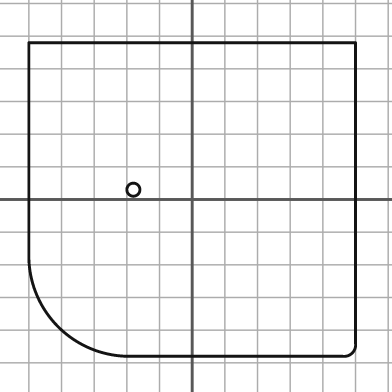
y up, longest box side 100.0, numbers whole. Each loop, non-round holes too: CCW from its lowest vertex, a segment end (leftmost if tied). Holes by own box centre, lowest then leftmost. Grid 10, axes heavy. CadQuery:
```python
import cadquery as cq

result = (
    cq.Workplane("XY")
    .moveTo(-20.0, -48.0)
    .lineTo(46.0, -48.0)
    .threePointArc((49.0, -47.0), (50.0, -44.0))
    .lineTo(50.0, 48.0)
    .lineTo(-50.0, 48.0)
    .lineTo(-50.0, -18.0)
    .threePointArc((-41.0, -39.0), (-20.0, -48.0))
    .close()
    .moveTo(-18.0, 3.0)
    .circle(2.0)
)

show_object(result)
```